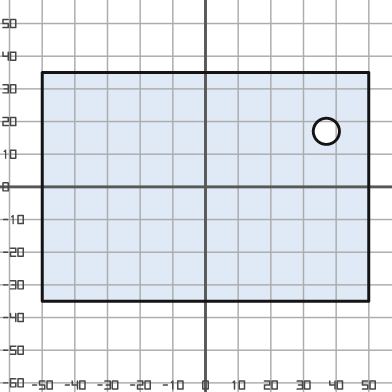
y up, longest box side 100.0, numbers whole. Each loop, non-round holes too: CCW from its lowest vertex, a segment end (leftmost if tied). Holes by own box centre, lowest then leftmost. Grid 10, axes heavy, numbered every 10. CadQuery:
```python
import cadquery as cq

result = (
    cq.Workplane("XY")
    .moveTo(-50.0, -35.0)
    .lineTo(50.0, -35.0)
    .lineTo(50.0, 35.0)
    .lineTo(-50.0, 35.0)
    .close()
    .moveTo(37.0, 17.0)
    .circle(4.0)
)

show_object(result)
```